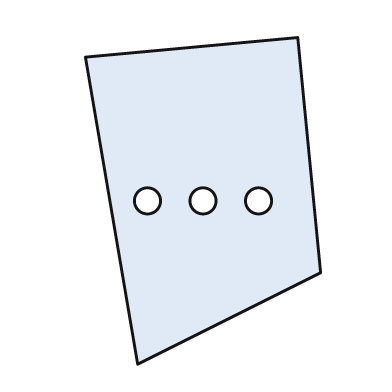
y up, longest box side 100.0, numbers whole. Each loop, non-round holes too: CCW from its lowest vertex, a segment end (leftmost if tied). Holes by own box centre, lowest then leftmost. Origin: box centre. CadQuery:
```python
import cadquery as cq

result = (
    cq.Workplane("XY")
    .moveTo(-20.0, -50.0)
    .lineTo(36.0, -22.0)
    .lineTo(29.0, 50.0)
    .lineTo(-36.0, 44.0)
    .close()
    .moveTo(-17.0, 0.0)
    .circle(4.0)
    .moveTo(0.0, 0.0)
    .circle(4.0)
    .moveTo(17.0, 0.0)
    .circle(4.0)
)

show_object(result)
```